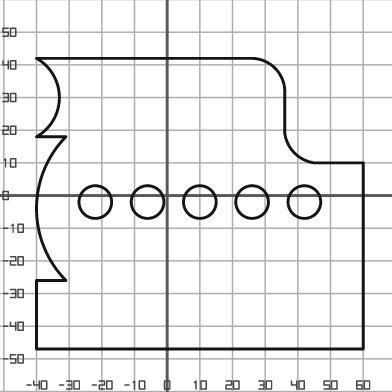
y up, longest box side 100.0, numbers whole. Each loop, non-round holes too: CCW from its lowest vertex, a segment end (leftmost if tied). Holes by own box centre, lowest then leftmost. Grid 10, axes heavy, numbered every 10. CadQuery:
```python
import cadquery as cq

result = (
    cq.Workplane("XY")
    .moveTo(-40.0, -47.0)
    .lineTo(60.0, -47.0)
    .lineTo(60.0, 10.0)
    .lineTo(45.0, 10.0)
    .threePointArc((39.0, 13.0), (36.0, 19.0))
    .lineTo(36.0, 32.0)
    .threePointArc((33.0, 39.0), (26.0, 42.0))
    .lineTo(-40.0, 42.0)
    .threePointArc((-33.0, 30.0), (-40.0, 18.0))
    .lineTo(-31.0, 18.0)
    .threePointArc((-40.0, -4.0), (-31.0, -26.0))
    .lineTo(-40.0, -26.0)
    .close()
    .moveTo(-22.0, -2.0)
    .circle(5.0)
    .moveTo(-6.0, -2.0)
    .circle(5.0)
    .moveTo(10.0, -2.0)
    .circle(5.0)
    .moveTo(26.0, -2.0)
    .circle(5.0)
    .moveTo(42.0, -2.0)
    .circle(5.0)
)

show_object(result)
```